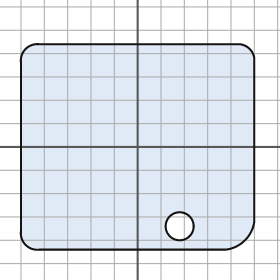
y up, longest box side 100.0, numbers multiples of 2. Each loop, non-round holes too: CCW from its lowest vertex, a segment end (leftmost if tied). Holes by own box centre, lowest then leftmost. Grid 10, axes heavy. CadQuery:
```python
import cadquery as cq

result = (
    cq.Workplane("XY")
    .moveTo(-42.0, -44.0)
    .lineTo(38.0, -44.0)
    .threePointArc((46.0, -40.0), (50.0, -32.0))
    .lineTo(50.0, 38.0)
    .threePointArc((48.0, 42.0), (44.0, 44.0))
    .lineTo(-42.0, 44.0)
    .threePointArc((-48.0, 42.0), (-50.0, 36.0))
    .lineTo(-50.0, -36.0)
    .threePointArc((-48.0, -42.0), (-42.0, -44.0))
    .close()
    .moveTo(18.0, -34.0)
    .circle(6.0)
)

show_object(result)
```